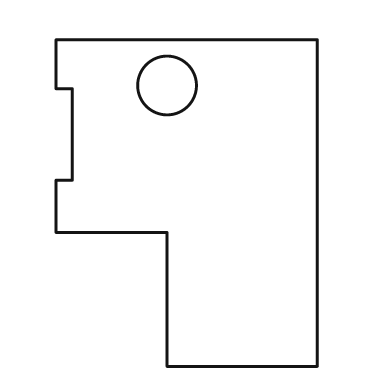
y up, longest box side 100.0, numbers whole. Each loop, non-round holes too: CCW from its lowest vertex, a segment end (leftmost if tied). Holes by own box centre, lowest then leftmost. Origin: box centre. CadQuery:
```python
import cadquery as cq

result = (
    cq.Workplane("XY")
    .moveTo(-6.0, -50.0)
    .lineTo(40.0, -50.0)
    .lineTo(40.0, 50.0)
    .lineTo(-40.0, 50.0)
    .lineTo(-40.0, 35.0)
    .lineTo(-35.0, 35.0)
    .lineTo(-35.0, 7.0)
    .lineTo(-40.0, 7.0)
    .lineTo(-40.0, -9.0)
    .lineTo(-6.0, -9.0)
    .close()
    .moveTo(-6.0, 36.0)
    .circle(9.0)
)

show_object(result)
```